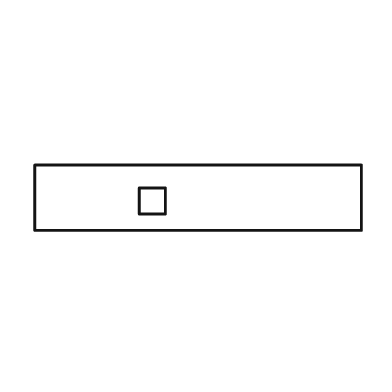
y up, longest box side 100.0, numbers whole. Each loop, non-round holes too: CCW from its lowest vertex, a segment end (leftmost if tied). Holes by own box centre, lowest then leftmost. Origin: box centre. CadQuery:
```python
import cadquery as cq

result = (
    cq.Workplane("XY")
    .moveTo(-50.0, -10.0)
    .lineTo(50.0, -10.0)
    .lineTo(50.0, 10.0)
    .lineTo(-50.0, 10.0)
    .close()
    .moveTo(-18.0, -5.0)
    .lineTo(-10.0, -5.0)
    .lineTo(-10.0, 3.0)
    .lineTo(-18.0, 3.0)
    .close()
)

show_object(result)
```